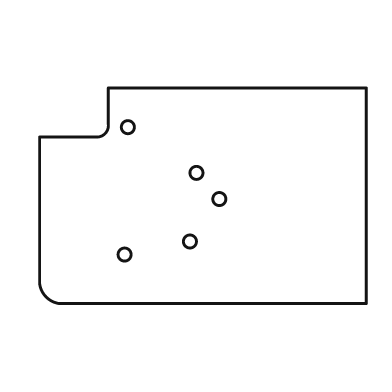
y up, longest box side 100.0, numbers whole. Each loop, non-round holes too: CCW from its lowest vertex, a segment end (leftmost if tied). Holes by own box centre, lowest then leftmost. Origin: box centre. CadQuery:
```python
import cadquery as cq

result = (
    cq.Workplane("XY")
    .moveTo(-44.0, -33.0)
    .lineTo(50.0, -33.0)
    .lineTo(50.0, 33.0)
    .lineTo(-29.0, 33.0)
    .lineTo(-29.0, 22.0)
    .threePointArc((-30.0, 19.0), (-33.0, 18.0))
    .lineTo(-50.0, 18.0)
    .lineTo(-50.0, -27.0)
    .threePointArc((-48.0, -31.0), (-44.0, -33.0))
    .close()
    .moveTo(-24.0, -18.0)
    .circle(2.0)
    .moveTo(-4.0, -14.0)
    .circle(2.0)
    .moveTo(5.0, -1.0)
    .circle(2.0)
    .moveTo(-2.0, 7.0)
    .circle(2.0)
    .moveTo(-23.0, 21.0)
    .circle(2.0)
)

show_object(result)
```